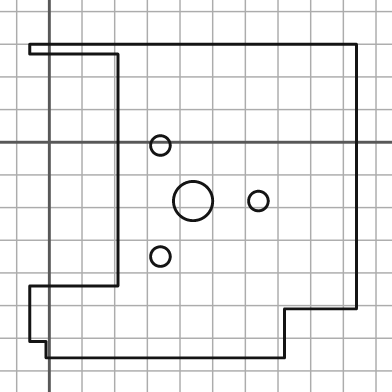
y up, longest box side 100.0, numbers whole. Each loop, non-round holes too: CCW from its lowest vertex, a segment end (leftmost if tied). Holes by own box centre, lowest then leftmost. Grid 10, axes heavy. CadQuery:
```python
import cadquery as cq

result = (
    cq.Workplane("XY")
    .moveTo(-1.0, -66.0)
    .lineTo(72.0, -66.0)
    .lineTo(72.0, -51.0)
    .lineTo(94.0, -51.0)
    .lineTo(94.0, 30.0)
    .lineTo(-6.0, 30.0)
    .lineTo(-6.0, 27.0)
    .lineTo(21.0, 27.0)
    .lineTo(21.0, -44.0)
    .lineTo(-6.0, -44.0)
    .lineTo(-6.0, -61.0)
    .lineTo(-1.0, -61.0)
    .close()
    .moveTo(34.0, -35.0)
    .circle(3.0)
    .moveTo(44.0, -18.0)
    .circle(6.0)
    .moveTo(64.0, -18.0)
    .circle(3.0)
    .moveTo(34.0, -1.0)
    .circle(3.0)
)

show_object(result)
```